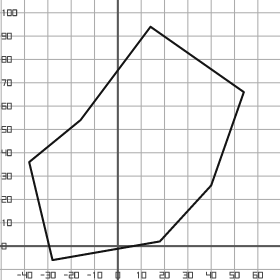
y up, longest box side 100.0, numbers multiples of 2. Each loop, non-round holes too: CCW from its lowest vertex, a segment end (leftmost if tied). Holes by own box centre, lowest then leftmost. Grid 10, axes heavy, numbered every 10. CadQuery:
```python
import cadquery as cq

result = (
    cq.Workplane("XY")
    .moveTo(-28.0, -6.0)
    .lineTo(18.0, 2.0)
    .lineTo(40.0, 26.0)
    .lineTo(54.0, 66.0)
    .lineTo(14.0, 94.0)
    .lineTo(-16.0, 54.0)
    .lineTo(-38.0, 36.0)
    .close()
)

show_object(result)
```